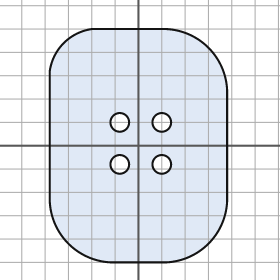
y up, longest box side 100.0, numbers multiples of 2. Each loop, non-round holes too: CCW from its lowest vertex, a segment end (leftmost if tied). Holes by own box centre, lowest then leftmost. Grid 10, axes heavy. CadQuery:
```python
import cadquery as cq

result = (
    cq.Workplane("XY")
    .moveTo(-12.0, -50.0)
    .lineTo(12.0, -50.0)
    .threePointArc((30.0, -42.0), (38.0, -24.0))
    .lineTo(38.0, 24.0)
    .threePointArc((30.0, 42.0), (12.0, 50.0))
    .lineTo(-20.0, 50.0)
    .threePointArc((-32.0, 44.0), (-38.0, 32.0))
    .lineTo(-38.0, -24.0)
    .threePointArc((-30.0, -42.0), (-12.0, -50.0))
    .close()
    .moveTo(-8.0, -8.0)
    .circle(4.0)
    .moveTo(10.0, -8.0)
    .circle(4.0)
    .moveTo(-8.0, 10.0)
    .circle(4.0)
    .moveTo(10.0, 10.0)
    .circle(4.0)
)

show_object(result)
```